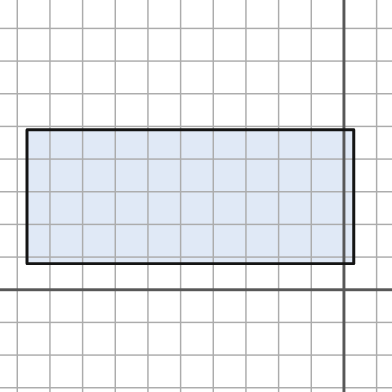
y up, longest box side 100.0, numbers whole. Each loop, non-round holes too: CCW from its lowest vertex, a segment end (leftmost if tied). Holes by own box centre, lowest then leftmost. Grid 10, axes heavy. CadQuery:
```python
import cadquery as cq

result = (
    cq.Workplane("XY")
    .moveTo(-97.0, 8.0)
    .lineTo(3.0, 8.0)
    .lineTo(3.0, 49.0)
    .lineTo(-97.0, 49.0)
    .close()
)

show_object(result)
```